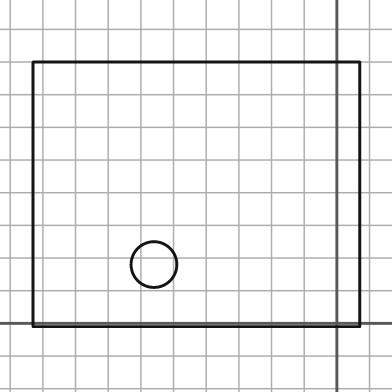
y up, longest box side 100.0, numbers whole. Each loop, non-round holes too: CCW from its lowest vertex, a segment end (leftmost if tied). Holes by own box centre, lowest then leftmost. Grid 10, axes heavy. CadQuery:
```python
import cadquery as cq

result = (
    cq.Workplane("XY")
    .moveTo(-93.0, -1.0)
    .lineTo(7.0, -1.0)
    .lineTo(7.0, 80.0)
    .lineTo(-93.0, 80.0)
    .close()
    .moveTo(-56.0, 18.0)
    .circle(7.0)
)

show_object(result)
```